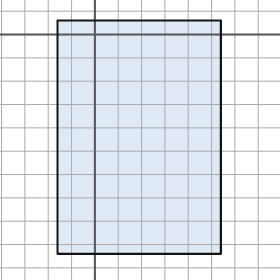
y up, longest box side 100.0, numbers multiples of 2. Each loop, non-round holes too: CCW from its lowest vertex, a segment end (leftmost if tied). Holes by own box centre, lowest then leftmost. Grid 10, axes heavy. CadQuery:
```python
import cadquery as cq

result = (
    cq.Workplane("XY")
    .moveTo(-16.0, -94.0)
    .lineTo(54.0, -94.0)
    .lineTo(54.0, 6.0)
    .lineTo(-16.0, 6.0)
    .close()
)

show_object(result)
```